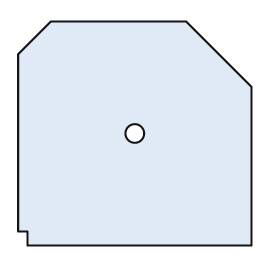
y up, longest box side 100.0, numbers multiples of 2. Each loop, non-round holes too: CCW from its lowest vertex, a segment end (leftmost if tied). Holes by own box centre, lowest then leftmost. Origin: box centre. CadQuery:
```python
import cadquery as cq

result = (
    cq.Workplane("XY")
    .moveTo(-46.0, -48.0)
    .lineTo(50.0, -48.0)
    .lineTo(50.0, 20.0)
    .lineTo(22.0, 48.0)
    .lineTo(-36.0, 48.0)
    .lineTo(-50.0, 34.0)
    .lineTo(-50.0, -42.0)
    .lineTo(-46.0, -42.0)
    .close()
    .moveTo(0.0, 0.0)
    .circle(4.0)
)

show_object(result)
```